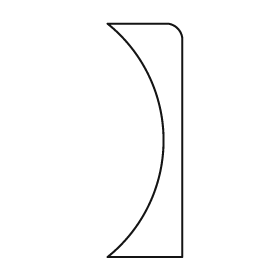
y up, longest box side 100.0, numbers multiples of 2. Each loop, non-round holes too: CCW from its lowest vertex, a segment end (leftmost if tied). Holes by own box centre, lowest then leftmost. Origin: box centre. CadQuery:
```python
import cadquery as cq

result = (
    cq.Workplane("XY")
    .moveTo(-16.0, -50.0)
    .lineTo(16.0, -50.0)
    .lineTo(16.0, 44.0)
    .threePointArc((14.0, 48.0), (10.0, 50.0))
    .lineTo(-16.0, 50.0)
    .threePointArc((8.0, 0.0), (-16.0, -50.0))
    .close()
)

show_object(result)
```